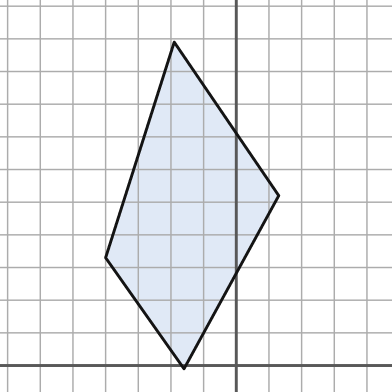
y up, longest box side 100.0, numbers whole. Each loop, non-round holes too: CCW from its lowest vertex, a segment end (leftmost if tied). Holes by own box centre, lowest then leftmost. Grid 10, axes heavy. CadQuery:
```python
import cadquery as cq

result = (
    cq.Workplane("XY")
    .moveTo(-16.0, -1.0)
    .lineTo(13.0, 52.0)
    .lineTo(-19.0, 99.0)
    .lineTo(-40.0, 33.0)
    .close()
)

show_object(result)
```